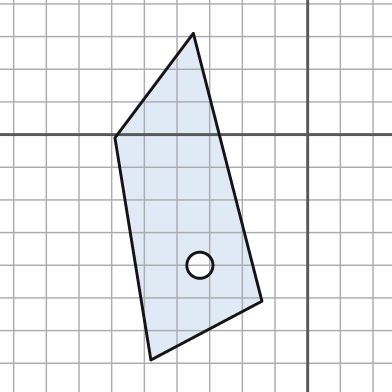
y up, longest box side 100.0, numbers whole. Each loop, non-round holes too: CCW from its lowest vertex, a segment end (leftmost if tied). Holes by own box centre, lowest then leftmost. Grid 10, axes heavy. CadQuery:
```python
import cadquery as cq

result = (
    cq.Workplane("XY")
    .moveTo(-48.0, -69.0)
    .lineTo(-14.0, -51.0)
    .lineTo(-35.0, 31.0)
    .lineTo(-59.0, -1.0)
    .close()
    .moveTo(-33.0, -40.0)
    .circle(4.0)
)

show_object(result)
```